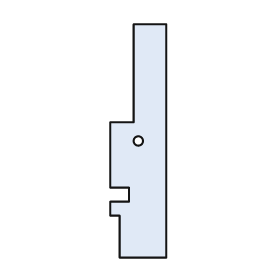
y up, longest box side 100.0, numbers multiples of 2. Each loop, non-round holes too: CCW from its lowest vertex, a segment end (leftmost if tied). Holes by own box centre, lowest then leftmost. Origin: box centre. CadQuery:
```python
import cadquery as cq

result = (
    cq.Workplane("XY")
    .moveTo(-8.0, -50.0)
    .lineTo(12.0, -50.0)
    .lineTo(12.0, 50.0)
    .lineTo(-2.0, 50.0)
    .lineTo(-2.0, 8.0)
    .lineTo(-12.0, 8.0)
    .lineTo(-12.0, -20.0)
    .lineTo(-4.0, -20.0)
    .lineTo(-4.0, -26.0)
    .lineTo(-12.0, -26.0)
    .lineTo(-12.0, -32.0)
    .lineTo(-8.0, -32.0)
    .close()
    .moveTo(0.0, 0.0)
    .circle(2.0)
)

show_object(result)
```